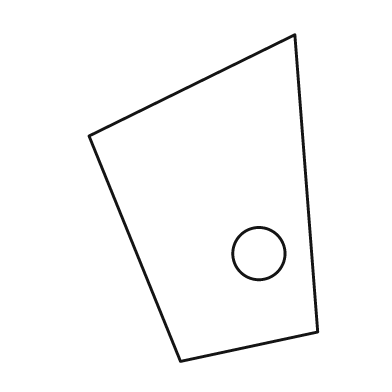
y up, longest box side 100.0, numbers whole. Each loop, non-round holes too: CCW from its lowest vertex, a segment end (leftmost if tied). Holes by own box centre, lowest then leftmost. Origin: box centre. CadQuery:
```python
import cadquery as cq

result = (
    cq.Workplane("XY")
    .moveTo(-7.0, -50.0)
    .lineTo(35.0, -41.0)
    .lineTo(28.0, 50.0)
    .lineTo(-35.0, 19.0)
    .close()
    .moveTo(17.0, -17.0)
    .circle(8.0)
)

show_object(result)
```